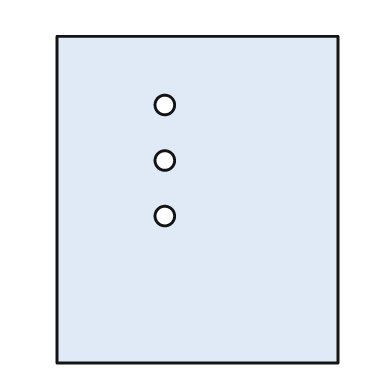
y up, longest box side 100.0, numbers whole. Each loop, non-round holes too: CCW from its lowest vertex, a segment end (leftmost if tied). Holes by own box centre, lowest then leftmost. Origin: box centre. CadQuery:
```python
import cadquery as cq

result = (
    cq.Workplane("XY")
    .moveTo(-43.0, -50.0)
    .lineTo(43.0, -50.0)
    .lineTo(43.0, 50.0)
    .lineTo(-43.0, 50.0)
    .close()
    .moveTo(-10.0, -5.0)
    .circle(3.0)
    .moveTo(-10.0, 12.0)
    .circle(3.0)
    .moveTo(-10.0, 29.0)
    .circle(3.0)
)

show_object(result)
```